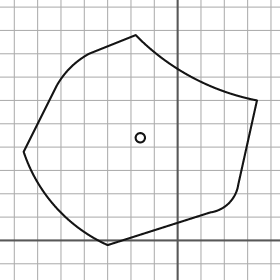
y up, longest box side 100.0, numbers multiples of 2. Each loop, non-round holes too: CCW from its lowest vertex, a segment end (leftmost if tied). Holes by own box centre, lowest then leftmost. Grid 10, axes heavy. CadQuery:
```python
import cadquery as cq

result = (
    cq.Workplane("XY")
    .moveTo(-30.0, -2.0)
    .lineTo(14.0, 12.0)
    .threePointArc((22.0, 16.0), (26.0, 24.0))
    .lineTo(34.0, 60.0)
    .threePointArc((6.0, 70.0), (-18.0, 88.0))
    .lineTo(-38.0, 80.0)
    .threePointArc((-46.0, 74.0), (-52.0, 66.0))
    .lineTo(-66.0, 38.0)
    .threePointArc((-52.0, 14.0), (-30.0, -2.0))
    .close()
    .moveTo(-16.0, 44.0)
    .circle(2.0)
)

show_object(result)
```